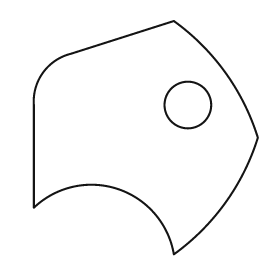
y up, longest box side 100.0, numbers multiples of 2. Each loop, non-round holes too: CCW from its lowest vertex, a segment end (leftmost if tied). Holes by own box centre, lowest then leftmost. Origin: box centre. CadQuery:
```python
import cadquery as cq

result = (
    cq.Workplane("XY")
    .moveTo(12.0, -50.0)
    .threePointArc((34.0, -28.0), (48.0, 0.0))
    .threePointArc((34.0, 28.0), (12.0, 50.0))
    .lineTo(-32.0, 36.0)
    .threePointArc((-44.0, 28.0), (-48.0, 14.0))
    .lineTo(-48.0, -30.0)
    .threePointArc((-12.0, -22.0), (12.0, -50.0))
    .close()
    .moveTo(18.0, 14.0)
    .circle(10.0)
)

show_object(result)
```